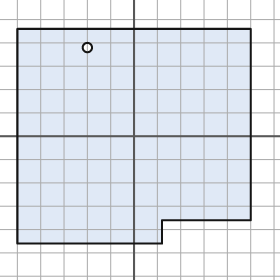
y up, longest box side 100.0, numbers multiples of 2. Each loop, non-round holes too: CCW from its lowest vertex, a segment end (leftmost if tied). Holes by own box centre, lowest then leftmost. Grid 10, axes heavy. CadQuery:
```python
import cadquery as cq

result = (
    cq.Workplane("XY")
    .moveTo(-50.0, -46.0)
    .lineTo(12.0, -46.0)
    .lineTo(12.0, -36.0)
    .lineTo(50.0, -36.0)
    .lineTo(50.0, 46.0)
    .lineTo(-50.0, 46.0)
    .close()
    .moveTo(-20.0, 38.0)
    .circle(2.0)
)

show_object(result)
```